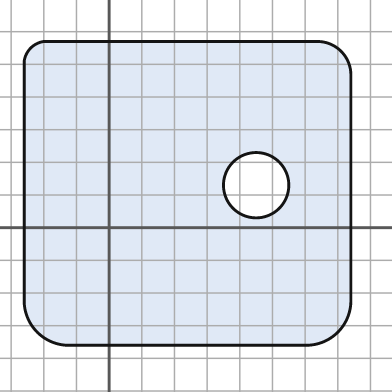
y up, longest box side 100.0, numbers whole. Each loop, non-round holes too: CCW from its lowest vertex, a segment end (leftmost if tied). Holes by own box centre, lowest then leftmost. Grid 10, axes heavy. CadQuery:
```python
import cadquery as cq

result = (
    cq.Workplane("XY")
    .moveTo(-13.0, -36.0)
    .lineTo(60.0, -36.0)
    .threePointArc((70.0, -32.0), (74.0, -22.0))
    .lineTo(74.0, 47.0)
    .threePointArc((71.0, 54.0), (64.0, 57.0))
    .lineTo(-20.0, 57.0)
    .threePointArc((-24.0, 55.0), (-26.0, 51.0))
    .lineTo(-26.0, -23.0)
    .threePointArc((-22.0, -32.0), (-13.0, -36.0))
    .close()
    .moveTo(45.0, 13.0)
    .circle(10.0)
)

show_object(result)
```